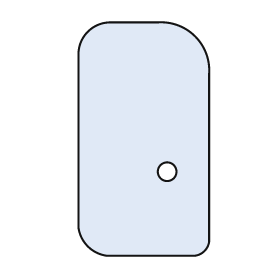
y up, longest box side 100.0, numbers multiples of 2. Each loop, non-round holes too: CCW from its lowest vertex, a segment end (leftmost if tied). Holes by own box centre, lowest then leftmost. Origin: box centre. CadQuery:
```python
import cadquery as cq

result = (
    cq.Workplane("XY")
    .moveTo(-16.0, -50.0)
    .lineTo(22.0, -50.0)
    .threePointArc((26.0, -48.0), (28.0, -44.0))
    .lineTo(28.0, 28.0)
    .threePointArc((22.0, 44.0), (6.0, 50.0))
    .lineTo(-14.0, 50.0)
    .threePointArc((-24.0, 46.0), (-28.0, 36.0))
    .lineTo(-28.0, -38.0)
    .threePointArc((-24.0, -46.0), (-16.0, -50.0))
    .close()
    .moveTo(10.0, -14.0)
    .circle(4.0)
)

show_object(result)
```